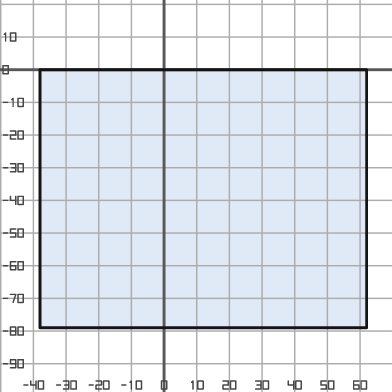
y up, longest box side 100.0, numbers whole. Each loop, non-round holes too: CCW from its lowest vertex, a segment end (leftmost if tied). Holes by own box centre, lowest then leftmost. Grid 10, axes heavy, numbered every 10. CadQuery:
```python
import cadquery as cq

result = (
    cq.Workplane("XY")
    .moveTo(-38.0, -79.0)
    .lineTo(62.0, -79.0)
    .lineTo(62.0, 0.0)
    .lineTo(-38.0, 0.0)
    .close()
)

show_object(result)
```